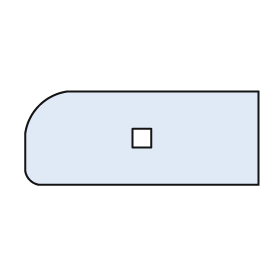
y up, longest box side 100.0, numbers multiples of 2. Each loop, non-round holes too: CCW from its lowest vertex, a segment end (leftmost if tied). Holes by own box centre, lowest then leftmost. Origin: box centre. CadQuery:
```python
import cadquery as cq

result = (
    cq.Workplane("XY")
    .moveTo(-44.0, -20.0)
    .lineTo(50.0, -20.0)
    .lineTo(50.0, 20.0)
    .lineTo(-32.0, 20.0)
    .threePointArc((-44.0, 14.0), (-50.0, 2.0))
    .lineTo(-50.0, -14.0)
    .threePointArc((-48.0, -18.0), (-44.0, -20.0))
    .close()
    .moveTo(-4.0, -4.0)
    .lineTo(4.0, -4.0)
    .lineTo(4.0, 4.0)
    .lineTo(-4.0, 4.0)
    .close()
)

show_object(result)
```